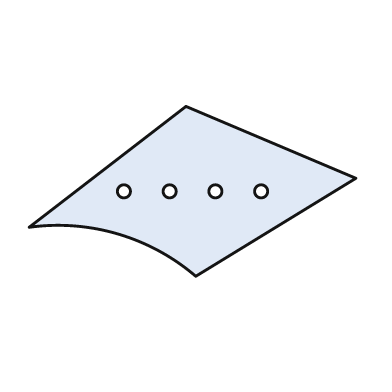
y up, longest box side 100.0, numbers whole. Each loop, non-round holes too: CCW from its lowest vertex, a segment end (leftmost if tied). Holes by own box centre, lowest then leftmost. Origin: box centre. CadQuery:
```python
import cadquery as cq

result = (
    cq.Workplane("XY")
    .moveTo(1.0, -26.0)
    .lineTo(50.0, 4.0)
    .lineTo(-2.0, 26.0)
    .lineTo(-50.0, -11.0)
    .threePointArc((-23.0, -13.0), (1.0, -26.0))
    .close()
    .moveTo(-21.0, 0.0)
    .circle(2.0)
    .moveTo(-7.0, 0.0)
    .circle(2.0)
    .moveTo(7.0, 0.0)
    .circle(2.0)
    .moveTo(21.0, 0.0)
    .circle(2.0)
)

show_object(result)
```